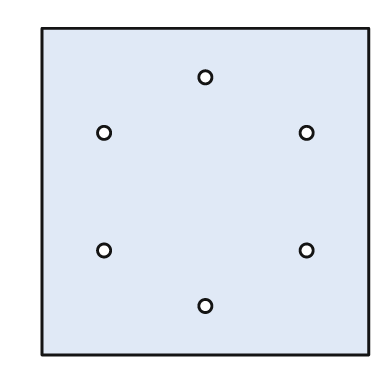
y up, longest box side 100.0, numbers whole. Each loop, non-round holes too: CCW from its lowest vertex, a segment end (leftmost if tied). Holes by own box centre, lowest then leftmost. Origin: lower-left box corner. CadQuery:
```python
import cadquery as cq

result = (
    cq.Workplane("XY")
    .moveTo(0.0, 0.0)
    .lineTo(100.0, 0.0)
    .lineTo(100.0, 100.0)
    .lineTo(0.0, 100.0)
    .close()
    .moveTo(50.0, 15.0)
    .circle(2.0)
    .moveTo(19.0, 32.0)
    .circle(2.0)
    .moveTo(81.0, 32.0)
    .circle(2.0)
    .moveTo(19.0, 68.0)
    .circle(2.0)
    .moveTo(81.0, 68.0)
    .circle(2.0)
    .moveTo(50.0, 85.0)
    .circle(2.0)
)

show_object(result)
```